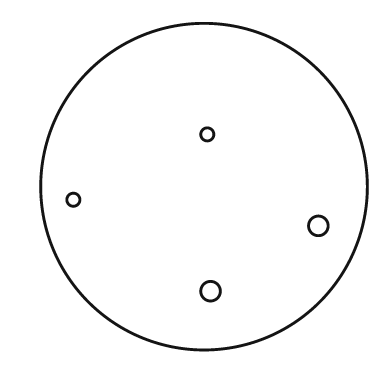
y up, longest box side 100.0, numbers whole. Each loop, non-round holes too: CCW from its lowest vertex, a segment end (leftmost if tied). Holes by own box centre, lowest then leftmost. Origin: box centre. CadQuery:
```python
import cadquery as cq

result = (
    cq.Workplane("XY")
    .moveTo(0.0, 0.0)
    .circle(50.0)
    .moveTo(2.0, -32.0)
    .circle(3.0)
    .moveTo(35.0, -12.0)
    .circle(3.0)
    .moveTo(-40.0, -4.0)
    .circle(2.0)
    .moveTo(1.0, 16.0)
    .circle(2.0)
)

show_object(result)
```